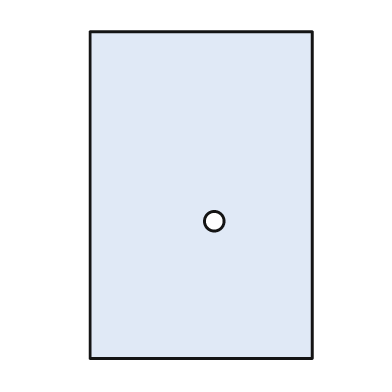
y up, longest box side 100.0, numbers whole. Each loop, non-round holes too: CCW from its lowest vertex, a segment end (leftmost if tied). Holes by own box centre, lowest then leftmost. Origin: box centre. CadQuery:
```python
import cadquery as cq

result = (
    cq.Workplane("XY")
    .moveTo(-34.0, -50.0)
    .lineTo(34.0, -50.0)
    .lineTo(34.0, 50.0)
    .lineTo(-34.0, 50.0)
    .close()
    .moveTo(4.0, -8.0)
    .circle(3.0)
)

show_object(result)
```